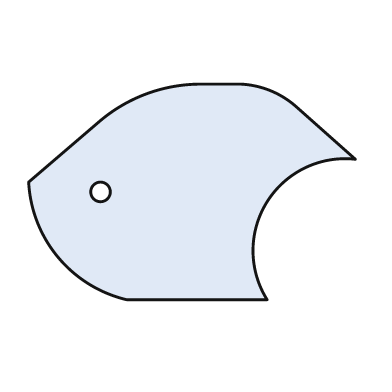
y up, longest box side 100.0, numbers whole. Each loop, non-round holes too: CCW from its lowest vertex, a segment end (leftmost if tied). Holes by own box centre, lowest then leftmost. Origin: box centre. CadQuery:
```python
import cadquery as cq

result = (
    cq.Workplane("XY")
    .moveTo(-20.0, -33.0)
    .lineTo(23.0, -33.0)
    .threePointArc((23.0, -3.0), (50.0, 10.0))
    .lineTo(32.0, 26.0)
    .threePointArc((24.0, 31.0), (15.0, 33.0))
    .lineTo(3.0, 33.0)
    .threePointArc((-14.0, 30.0), (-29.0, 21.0))
    .lineTo(-50.0, 3.0)
    .threePointArc((-41.0, -20.0), (-20.0, -33.0))
    .close()
    .moveTo(-28.0, 0.0)
    .circle(3.0)
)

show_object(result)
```